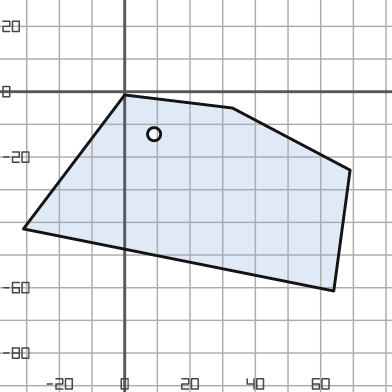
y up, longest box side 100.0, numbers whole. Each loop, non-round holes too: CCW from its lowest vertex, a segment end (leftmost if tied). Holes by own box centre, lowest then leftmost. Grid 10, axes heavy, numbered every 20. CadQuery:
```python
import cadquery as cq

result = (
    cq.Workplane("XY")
    .moveTo(64.0, -61.0)
    .lineTo(69.0, -24.0)
    .lineTo(33.0, -5.0)
    .lineTo(0.0, -1.0)
    .lineTo(-31.0, -42.0)
    .close()
    .moveTo(9.0, -13.0)
    .circle(2.0)
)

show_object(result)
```